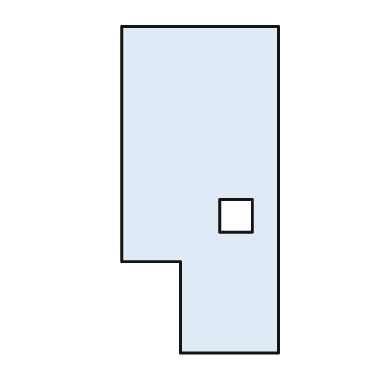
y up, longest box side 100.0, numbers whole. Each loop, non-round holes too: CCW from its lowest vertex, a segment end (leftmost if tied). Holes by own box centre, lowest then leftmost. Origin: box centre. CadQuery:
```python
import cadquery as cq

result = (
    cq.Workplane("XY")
    .moveTo(-6.0, -50.0)
    .lineTo(24.0, -50.0)
    .lineTo(24.0, 50.0)
    .lineTo(-24.0, 50.0)
    .lineTo(-24.0, -22.0)
    .lineTo(-6.0, -22.0)
    .close()
    .moveTo(6.0, -13.0)
    .lineTo(16.0, -13.0)
    .lineTo(16.0, -3.0)
    .lineTo(6.0, -3.0)
    .close()
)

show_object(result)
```